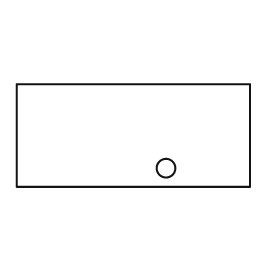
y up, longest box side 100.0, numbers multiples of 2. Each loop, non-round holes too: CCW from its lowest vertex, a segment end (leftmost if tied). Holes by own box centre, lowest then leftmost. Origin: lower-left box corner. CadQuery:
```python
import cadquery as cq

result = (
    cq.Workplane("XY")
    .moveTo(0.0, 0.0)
    .lineTo(100.0, 0.0)
    .lineTo(100.0, 44.0)
    .lineTo(0.0, 44.0)
    .close()
    .moveTo(64.0, 8.0)
    .circle(4.0)
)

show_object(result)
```